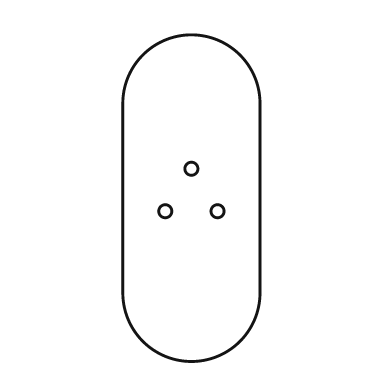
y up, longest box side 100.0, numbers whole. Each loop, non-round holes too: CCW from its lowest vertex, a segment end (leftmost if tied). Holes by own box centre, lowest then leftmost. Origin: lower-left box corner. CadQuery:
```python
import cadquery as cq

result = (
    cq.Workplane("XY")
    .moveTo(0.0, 21.0)
    .threePointArc((21.0, 0.0), (42.0, 21.0))
    .lineTo(42.0, 79.0)
    .threePointArc((21.0, 100.0), (0.0, 79.0))
    .close()
    .moveTo(13.0, 46.0)
    .circle(2.0)
    .moveTo(29.0, 46.0)
    .circle(2.0)
    .moveTo(21.0, 59.0)
    .circle(2.0)
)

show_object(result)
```